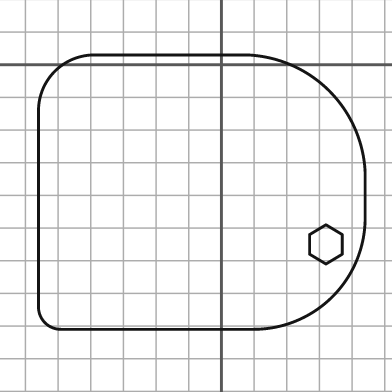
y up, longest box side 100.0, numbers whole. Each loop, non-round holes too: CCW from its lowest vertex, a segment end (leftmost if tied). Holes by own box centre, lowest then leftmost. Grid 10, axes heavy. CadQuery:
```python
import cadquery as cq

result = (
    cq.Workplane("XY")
    .moveTo(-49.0, -81.0)
    .lineTo(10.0, -81.0)
    .threePointArc((34.0, -71.0), (44.0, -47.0))
    .lineTo(44.0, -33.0)
    .threePointArc((33.0, -8.0), (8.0, 3.0))
    .lineTo(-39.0, 3.0)
    .threePointArc((-51.0, -2.0), (-56.0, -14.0))
    .lineTo(-56.0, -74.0)
    .threePointArc((-54.0, -79.0), (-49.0, -81.0))
    .close()
    .moveTo(32.0, -61.0)
    .lineTo(37.0, -58.0)
    .lineTo(37.0, -52.0)
    .lineTo(32.0, -49.0)
    .lineTo(27.0, -52.0)
    .lineTo(27.0, -58.0)
    .close()
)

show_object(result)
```